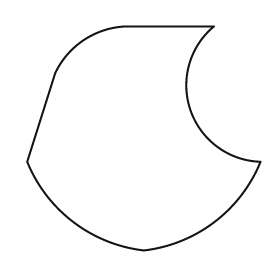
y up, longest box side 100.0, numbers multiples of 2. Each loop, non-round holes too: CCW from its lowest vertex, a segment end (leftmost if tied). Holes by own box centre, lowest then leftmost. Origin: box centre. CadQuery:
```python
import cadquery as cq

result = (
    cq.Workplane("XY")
    .moveTo(0.0, -48.0)
    .threePointArc((30.0, -36.0), (50.0, -10.0))
    .threePointArc((20.0, 12.0), (30.0, 48.0))
    .lineTo(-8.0, 48.0)
    .threePointArc((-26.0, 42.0), (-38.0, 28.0))
    .lineTo(-50.0, -10.0)
    .threePointArc((-30.0, -36.0), (0.0, -48.0))
    .close()
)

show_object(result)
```